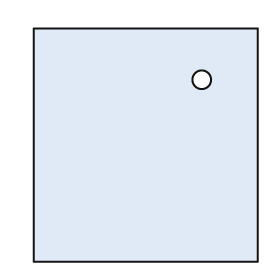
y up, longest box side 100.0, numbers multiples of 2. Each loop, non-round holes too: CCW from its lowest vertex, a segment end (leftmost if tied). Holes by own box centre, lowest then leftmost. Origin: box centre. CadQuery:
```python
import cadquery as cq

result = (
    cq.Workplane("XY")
    .moveTo(-48.0, -50.0)
    .lineTo(48.0, -50.0)
    .lineTo(48.0, 50.0)
    .lineTo(-48.0, 50.0)
    .close()
    .moveTo(24.0, 28.0)
    .circle(4.0)
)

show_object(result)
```